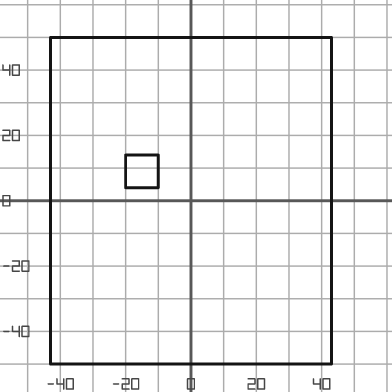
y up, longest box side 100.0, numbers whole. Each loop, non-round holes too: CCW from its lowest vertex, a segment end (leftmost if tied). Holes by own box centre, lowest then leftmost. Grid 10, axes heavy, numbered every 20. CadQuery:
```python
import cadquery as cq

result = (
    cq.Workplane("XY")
    .moveTo(-43.0, -50.0)
    .lineTo(43.0, -50.0)
    .lineTo(43.0, 50.0)
    .lineTo(-43.0, 50.0)
    .close()
    .moveTo(-20.0, 4.0)
    .lineTo(-10.0, 4.0)
    .lineTo(-10.0, 14.0)
    .lineTo(-20.0, 14.0)
    .close()
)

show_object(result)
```